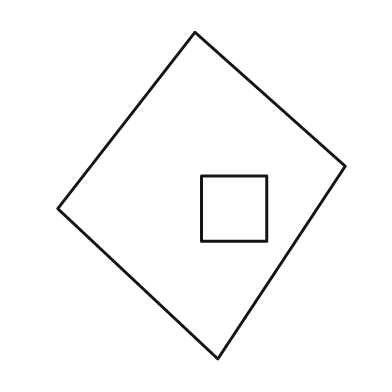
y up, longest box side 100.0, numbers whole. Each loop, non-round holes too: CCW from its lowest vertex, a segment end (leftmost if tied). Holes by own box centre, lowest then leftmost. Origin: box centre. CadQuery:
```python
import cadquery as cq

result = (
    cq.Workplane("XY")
    .moveTo(5.0, -50.0)
    .lineTo(44.0, 9.0)
    .lineTo(-2.0, 50.0)
    .lineTo(-44.0, -4.0)
    .close()
    .moveTo(0.0, -14.0)
    .lineTo(20.0, -14.0)
    .lineTo(20.0, 6.0)
    .lineTo(0.0, 6.0)
    .close()
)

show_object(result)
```